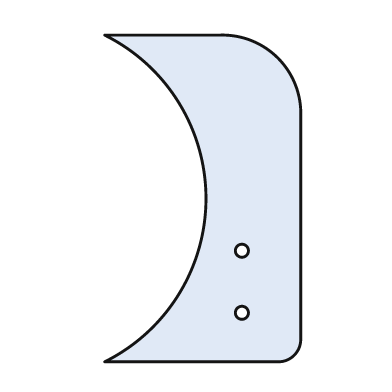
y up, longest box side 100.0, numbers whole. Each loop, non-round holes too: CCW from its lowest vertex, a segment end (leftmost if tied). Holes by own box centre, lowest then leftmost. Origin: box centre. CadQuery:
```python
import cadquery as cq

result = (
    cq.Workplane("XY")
    .moveTo(-30.0, -50.0)
    .lineTo(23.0, -50.0)
    .threePointArc((28.0, -48.0), (30.0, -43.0))
    .lineTo(30.0, 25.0)
    .threePointArc((23.0, 43.0), (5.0, 50.0))
    .lineTo(-30.0, 50.0)
    .threePointArc((1.0, 0.0), (-30.0, -50.0))
    .close()
    .moveTo(12.0, -35.0)
    .circle(2.0)
    .moveTo(12.0, -16.0)
    .circle(2.0)
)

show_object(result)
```